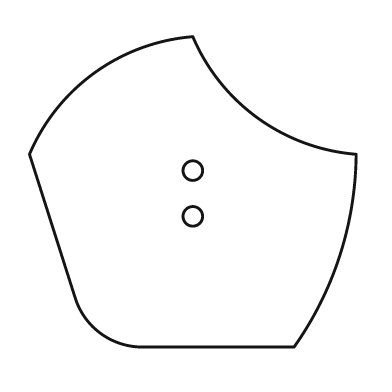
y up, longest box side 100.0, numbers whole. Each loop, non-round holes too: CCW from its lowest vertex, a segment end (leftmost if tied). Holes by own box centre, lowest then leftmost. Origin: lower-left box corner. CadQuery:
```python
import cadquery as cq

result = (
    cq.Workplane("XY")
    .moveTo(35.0, 0.0)
    .lineTo(81.0, 0.0)
    .threePointArc((95.0, 28.0), (100.0, 59.0))
    .threePointArc((70.0, 70.0), (50.0, 95.0))
    .threePointArc((20.0, 84.0), (0.0, 59.0))
    .lineTo(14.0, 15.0)
    .threePointArc((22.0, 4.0), (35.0, 0.0))
    .close()
    .moveTo(50.0, 40.0)
    .circle(3.0)
    .moveTo(50.0, 54.0)
    .circle(3.0)
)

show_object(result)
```